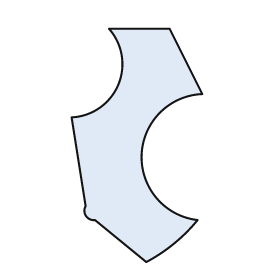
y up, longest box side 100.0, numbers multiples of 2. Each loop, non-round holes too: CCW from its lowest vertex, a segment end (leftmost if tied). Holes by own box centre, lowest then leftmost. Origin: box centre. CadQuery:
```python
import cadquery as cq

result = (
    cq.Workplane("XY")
    .moveTo(4.0, -50.0)
    .threePointArc((16.0, -42.0), (26.0, -32.0))
    .threePointArc((2.0, -4.0), (28.0, 22.0))
    .lineTo(14.0, 50.0)
    .lineTo(-12.0, 50.0)
    .threePointArc((-8.0, 26.0), (-28.0, 12.0))
    .lineTo(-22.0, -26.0)
    .threePointArc((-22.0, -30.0), (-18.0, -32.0))
    .close()
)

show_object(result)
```